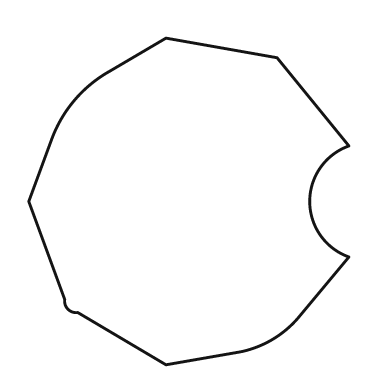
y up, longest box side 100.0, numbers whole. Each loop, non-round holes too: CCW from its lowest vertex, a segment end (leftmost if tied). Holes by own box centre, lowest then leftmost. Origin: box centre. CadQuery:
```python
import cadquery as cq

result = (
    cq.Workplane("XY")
    .moveTo(-7.0, -50.0)
    .lineTo(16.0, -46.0)
    .threePointArc((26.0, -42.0), (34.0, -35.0))
    .lineTo(49.0, -17.0)
    .threePointArc((37.0, 0.0), (49.0, 17.0))
    .lineTo(27.0, 44.0)
    .lineTo(-7.0, 50.0)
    .lineTo(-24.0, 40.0)
    .threePointArc((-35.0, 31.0), (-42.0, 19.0))
    .lineTo(-49.0, 0.0)
    .lineTo(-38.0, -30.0)
    .threePointArc((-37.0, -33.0), (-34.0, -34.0))
    .close()
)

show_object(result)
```